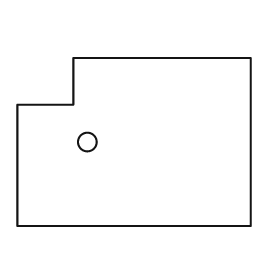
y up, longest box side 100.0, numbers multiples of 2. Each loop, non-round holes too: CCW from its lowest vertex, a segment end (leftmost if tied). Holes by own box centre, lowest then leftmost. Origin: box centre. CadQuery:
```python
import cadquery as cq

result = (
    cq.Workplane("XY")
    .moveTo(-50.0, -36.0)
    .lineTo(50.0, -36.0)
    .lineTo(50.0, 36.0)
    .lineTo(-26.0, 36.0)
    .lineTo(-26.0, 16.0)
    .lineTo(-50.0, 16.0)
    .close()
    .moveTo(-20.0, 0.0)
    .circle(4.0)
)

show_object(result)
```